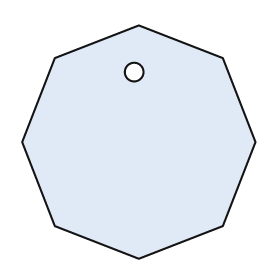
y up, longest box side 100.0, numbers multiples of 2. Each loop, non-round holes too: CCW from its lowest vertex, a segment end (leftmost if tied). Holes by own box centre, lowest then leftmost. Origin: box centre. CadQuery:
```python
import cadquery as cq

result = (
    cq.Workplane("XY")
    .moveTo(0.0, -50.0)
    .lineTo(36.0, -36.0)
    .lineTo(50.0, 0.0)
    .lineTo(36.0, 36.0)
    .lineTo(0.0, 50.0)
    .lineTo(-36.0, 36.0)
    .lineTo(-50.0, 0.0)
    .lineTo(-36.0, -36.0)
    .close()
    .moveTo(-2.0, 30.0)
    .circle(4.0)
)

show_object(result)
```